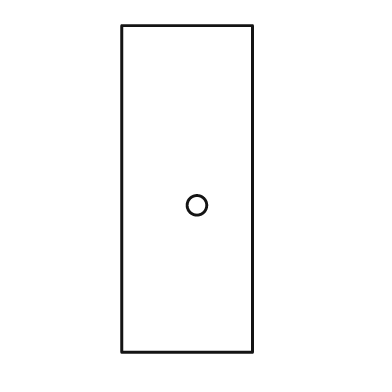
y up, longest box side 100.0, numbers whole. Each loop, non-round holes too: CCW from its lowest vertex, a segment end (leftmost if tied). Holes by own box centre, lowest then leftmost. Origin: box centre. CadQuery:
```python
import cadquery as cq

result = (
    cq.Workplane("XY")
    .moveTo(-20.0, -50.0)
    .lineTo(20.0, -50.0)
    .lineTo(20.0, 50.0)
    .lineTo(-20.0, 50.0)
    .close()
    .moveTo(3.0, -5.0)
    .circle(3.0)
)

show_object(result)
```